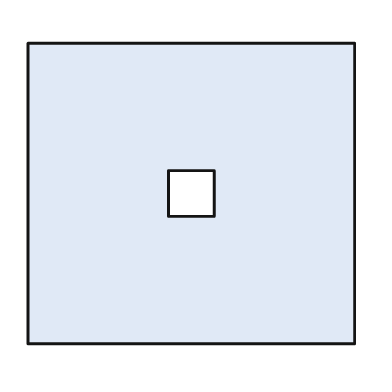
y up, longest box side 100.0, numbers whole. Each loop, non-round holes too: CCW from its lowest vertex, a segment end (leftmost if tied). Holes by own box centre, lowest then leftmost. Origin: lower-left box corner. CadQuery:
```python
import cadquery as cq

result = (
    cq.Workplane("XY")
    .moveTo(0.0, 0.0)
    .lineTo(100.0, 0.0)
    .lineTo(100.0, 92.0)
    .lineTo(0.0, 92.0)
    .close()
    .moveTo(43.0, 39.0)
    .lineTo(57.0, 39.0)
    .lineTo(57.0, 53.0)
    .lineTo(43.0, 53.0)
    .close()
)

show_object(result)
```